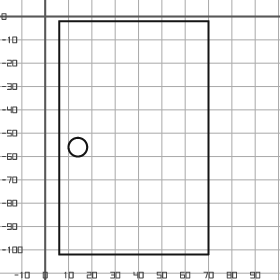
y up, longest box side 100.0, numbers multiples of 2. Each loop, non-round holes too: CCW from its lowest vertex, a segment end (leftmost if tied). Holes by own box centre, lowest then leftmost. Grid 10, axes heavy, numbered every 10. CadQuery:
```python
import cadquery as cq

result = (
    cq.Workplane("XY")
    .moveTo(6.0, -102.0)
    .lineTo(70.0, -102.0)
    .lineTo(70.0, -2.0)
    .lineTo(6.0, -2.0)
    .close()
    .moveTo(14.0, -56.0)
    .circle(4.0)
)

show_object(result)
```